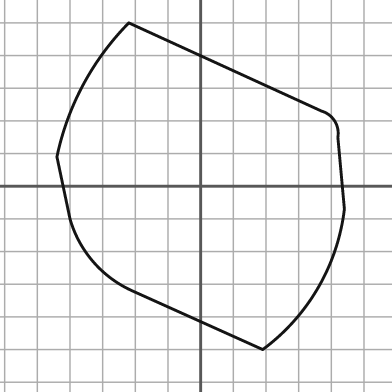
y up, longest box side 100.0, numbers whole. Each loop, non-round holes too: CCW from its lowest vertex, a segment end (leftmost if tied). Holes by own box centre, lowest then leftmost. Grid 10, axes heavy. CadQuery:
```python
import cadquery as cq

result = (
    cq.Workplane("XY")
    .moveTo(19.0, -50.0)
    .threePointArc((36.0, -31.0), (44.0, -7.0))
    .lineTo(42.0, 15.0)
    .threePointArc((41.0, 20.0), (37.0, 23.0))
    .lineTo(-22.0, 50.0)
    .threePointArc((-36.0, 31.0), (-44.0, 9.0))
    .lineTo(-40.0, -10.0)
    .threePointArc((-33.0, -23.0), (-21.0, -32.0))
    .close()
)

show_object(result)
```